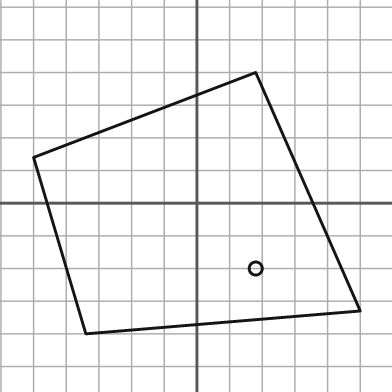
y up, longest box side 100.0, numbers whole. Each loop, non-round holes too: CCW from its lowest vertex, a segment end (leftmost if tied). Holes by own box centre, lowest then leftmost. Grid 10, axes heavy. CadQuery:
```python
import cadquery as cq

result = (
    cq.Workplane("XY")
    .moveTo(-34.0, -40.0)
    .lineTo(50.0, -33.0)
    .lineTo(18.0, 40.0)
    .lineTo(-50.0, 14.0)
    .close()
    .moveTo(18.0, -20.0)
    .circle(2.0)
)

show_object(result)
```